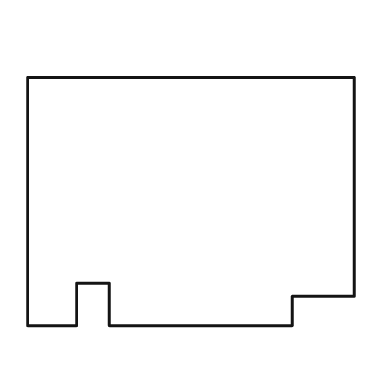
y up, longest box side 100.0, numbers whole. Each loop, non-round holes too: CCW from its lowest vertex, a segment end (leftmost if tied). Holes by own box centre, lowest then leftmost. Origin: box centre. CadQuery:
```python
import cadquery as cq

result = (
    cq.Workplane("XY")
    .moveTo(-50.0, -38.0)
    .lineTo(-35.0, -38.0)
    .lineTo(-35.0, -25.0)
    .lineTo(-25.0, -25.0)
    .lineTo(-25.0, -38.0)
    .lineTo(31.0, -38.0)
    .lineTo(31.0, -29.0)
    .lineTo(50.0, -29.0)
    .lineTo(50.0, 38.0)
    .lineTo(-50.0, 38.0)
    .close()
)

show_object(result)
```